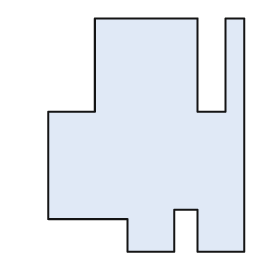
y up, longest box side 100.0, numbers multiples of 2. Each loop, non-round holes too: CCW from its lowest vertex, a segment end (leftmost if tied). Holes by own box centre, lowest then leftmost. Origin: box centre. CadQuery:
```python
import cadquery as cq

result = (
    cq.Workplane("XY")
    .moveTo(-8.0, -50.0)
    .lineTo(12.0, -50.0)
    .lineTo(12.0, -32.0)
    .lineTo(22.0, -32.0)
    .lineTo(22.0, -50.0)
    .lineTo(42.0, -50.0)
    .lineTo(42.0, 50.0)
    .lineTo(34.0, 50.0)
    .lineTo(34.0, 10.0)
    .lineTo(22.0, 10.0)
    .lineTo(22.0, 50.0)
    .lineTo(-22.0, 50.0)
    .lineTo(-22.0, 10.0)
    .lineTo(-42.0, 10.0)
    .lineTo(-42.0, -36.0)
    .lineTo(-8.0, -36.0)
    .close()
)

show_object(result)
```